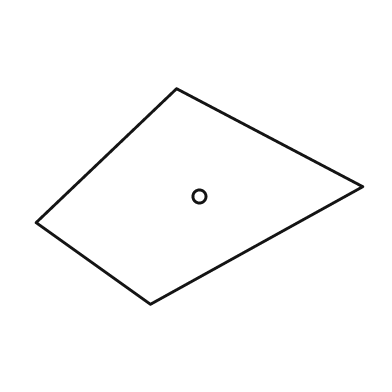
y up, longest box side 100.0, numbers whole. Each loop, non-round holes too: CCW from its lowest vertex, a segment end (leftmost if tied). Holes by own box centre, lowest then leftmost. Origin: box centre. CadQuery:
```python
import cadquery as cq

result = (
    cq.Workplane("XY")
    .moveTo(-15.0, -33.0)
    .lineTo(50.0, 3.0)
    .lineTo(-7.0, 33.0)
    .lineTo(-50.0, -8.0)
    .close()
    .moveTo(0.0, 0.0)
    .circle(2.0)
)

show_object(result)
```